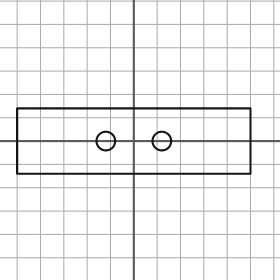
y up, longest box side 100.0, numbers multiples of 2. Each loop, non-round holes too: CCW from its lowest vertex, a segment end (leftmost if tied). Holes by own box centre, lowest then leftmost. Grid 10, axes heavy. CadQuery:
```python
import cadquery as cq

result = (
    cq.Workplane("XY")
    .moveTo(-50.0, -14.0)
    .lineTo(50.0, -14.0)
    .lineTo(50.0, 14.0)
    .lineTo(-50.0, 14.0)
    .close()
    .moveTo(-12.0, 0.0)
    .circle(4.0)
    .moveTo(12.0, 0.0)
    .circle(4.0)
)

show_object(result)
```